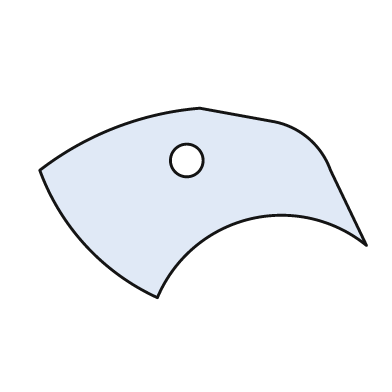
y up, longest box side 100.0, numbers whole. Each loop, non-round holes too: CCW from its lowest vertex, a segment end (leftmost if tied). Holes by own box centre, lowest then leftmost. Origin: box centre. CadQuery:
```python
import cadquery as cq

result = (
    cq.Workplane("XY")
    .moveTo(-14.0, -29.0)
    .threePointArc((14.0, -5.0), (50.0, -13.0))
    .lineTo(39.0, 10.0)
    .threePointArc((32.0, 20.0), (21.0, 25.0))
    .lineTo(-1.0, 29.0)
    .threePointArc((-27.0, 23.0), (-50.0, 10.0))
    .threePointArc((-36.0, -13.0), (-14.0, -29.0))
    .close()
    .moveTo(-5.0, 13.0)
    .circle(5.0)
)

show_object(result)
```